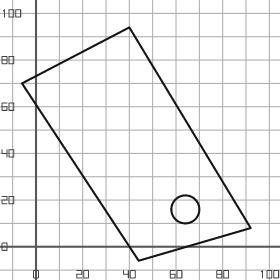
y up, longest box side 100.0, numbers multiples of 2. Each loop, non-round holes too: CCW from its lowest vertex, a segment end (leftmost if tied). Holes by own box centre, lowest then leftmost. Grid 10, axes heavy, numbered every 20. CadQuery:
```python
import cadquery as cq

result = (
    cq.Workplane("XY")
    .moveTo(44.0, -6.0)
    .lineTo(92.0, 8.0)
    .lineTo(40.0, 94.0)
    .lineTo(-6.0, 70.0)
    .close()
    .moveTo(64.0, 16.0)
    .circle(6.0)
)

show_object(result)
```